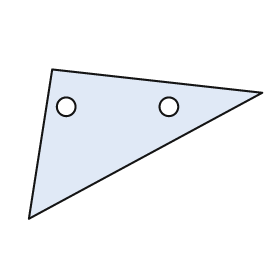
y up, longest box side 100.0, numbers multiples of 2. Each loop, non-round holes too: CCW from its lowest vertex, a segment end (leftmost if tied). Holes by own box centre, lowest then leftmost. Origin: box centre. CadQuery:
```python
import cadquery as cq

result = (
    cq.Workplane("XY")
    .moveTo(-50.0, -32.0)
    .lineTo(50.0, 22.0)
    .lineTo(-40.0, 32.0)
    .close()
    .moveTo(-34.0, 16.0)
    .circle(4.0)
    .moveTo(10.0, 16.0)
    .circle(4.0)
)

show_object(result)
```